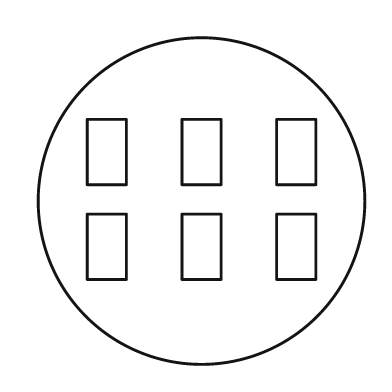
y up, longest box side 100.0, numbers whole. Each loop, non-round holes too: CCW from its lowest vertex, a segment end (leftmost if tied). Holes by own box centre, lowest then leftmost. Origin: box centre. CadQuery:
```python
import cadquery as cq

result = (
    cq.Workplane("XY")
    .moveTo(0.0, 0.0)
    .circle(50.0)
    .moveTo(-35.0, -24.0)
    .lineTo(-23.0, -24.0)
    .lineTo(-23.0, -4.0)
    .lineTo(-35.0, -4.0)
    .close()
    .moveTo(-6.0, -24.0)
    .lineTo(6.0, -24.0)
    .lineTo(6.0, -4.0)
    .lineTo(-6.0, -4.0)
    .close()
    .moveTo(23.0, -24.0)
    .lineTo(35.0, -24.0)
    .lineTo(35.0, -4.0)
    .lineTo(23.0, -4.0)
    .close()
    .moveTo(-35.0, 5.0)
    .lineTo(-23.0, 5.0)
    .lineTo(-23.0, 25.0)
    .lineTo(-35.0, 25.0)
    .close()
    .moveTo(-6.0, 5.0)
    .lineTo(6.0, 5.0)
    .lineTo(6.0, 25.0)
    .lineTo(-6.0, 25.0)
    .close()
    .moveTo(23.0, 5.0)
    .lineTo(35.0, 5.0)
    .lineTo(35.0, 25.0)
    .lineTo(23.0, 25.0)
    .close()
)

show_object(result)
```